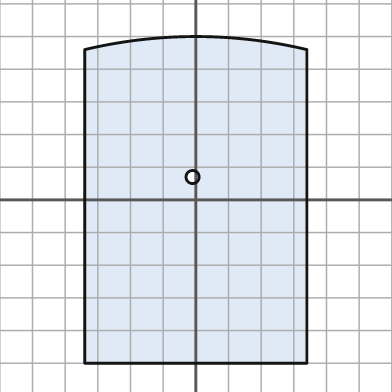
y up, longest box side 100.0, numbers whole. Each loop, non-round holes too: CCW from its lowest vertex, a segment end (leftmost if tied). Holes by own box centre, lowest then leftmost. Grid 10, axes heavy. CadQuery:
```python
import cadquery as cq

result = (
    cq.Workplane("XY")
    .moveTo(-34.0, -50.0)
    .lineTo(34.0, -50.0)
    .lineTo(34.0, 46.0)
    .threePointArc((0.0, 50.0), (-34.0, 46.0))
    .close()
    .moveTo(-1.0, 7.0)
    .circle(2.0)
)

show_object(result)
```